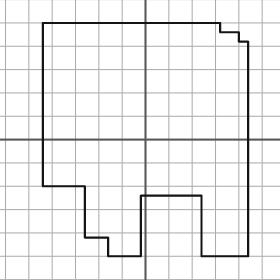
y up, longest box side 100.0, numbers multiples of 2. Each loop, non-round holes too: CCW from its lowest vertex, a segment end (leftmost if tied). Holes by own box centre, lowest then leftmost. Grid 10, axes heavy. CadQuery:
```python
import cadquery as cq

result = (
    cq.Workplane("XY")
    .moveTo(-16.0, -50.0)
    .lineTo(-2.0, -50.0)
    .lineTo(-2.0, -24.0)
    .lineTo(24.0, -24.0)
    .lineTo(24.0, -50.0)
    .lineTo(44.0, -50.0)
    .lineTo(44.0, 42.0)
    .lineTo(40.0, 42.0)
    .lineTo(40.0, 46.0)
    .lineTo(32.0, 46.0)
    .lineTo(32.0, 50.0)
    .lineTo(-44.0, 50.0)
    .lineTo(-44.0, -20.0)
    .lineTo(-26.0, -20.0)
    .lineTo(-26.0, -42.0)
    .lineTo(-16.0, -42.0)
    .close()
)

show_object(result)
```